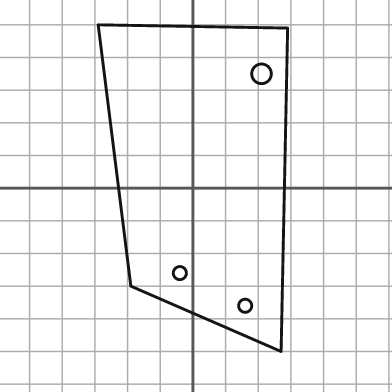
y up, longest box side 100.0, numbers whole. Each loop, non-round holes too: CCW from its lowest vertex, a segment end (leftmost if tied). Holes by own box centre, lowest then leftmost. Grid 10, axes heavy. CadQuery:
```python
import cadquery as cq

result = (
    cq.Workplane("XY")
    .moveTo(27.0, -50.0)
    .lineTo(29.0, 49.0)
    .lineTo(-29.0, 50.0)
    .lineTo(-19.0, -30.0)
    .close()
    .moveTo(16.0, -36.0)
    .circle(2.0)
    .moveTo(-4.0, -26.0)
    .circle(2.0)
    .moveTo(21.0, 35.0)
    .circle(3.0)
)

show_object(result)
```